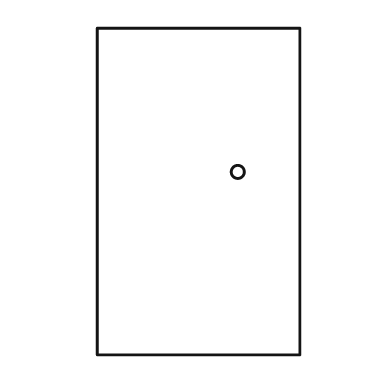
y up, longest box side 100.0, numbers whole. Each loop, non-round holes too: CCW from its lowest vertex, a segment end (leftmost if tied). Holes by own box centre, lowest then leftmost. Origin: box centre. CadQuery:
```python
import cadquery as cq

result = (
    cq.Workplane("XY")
    .moveTo(-31.0, -50.0)
    .lineTo(31.0, -50.0)
    .lineTo(31.0, 50.0)
    .lineTo(-31.0, 50.0)
    .close()
    .moveTo(12.0, 6.0)
    .circle(2.0)
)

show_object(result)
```